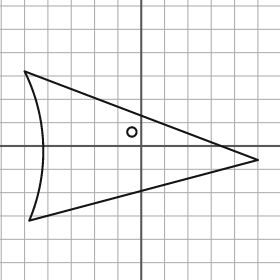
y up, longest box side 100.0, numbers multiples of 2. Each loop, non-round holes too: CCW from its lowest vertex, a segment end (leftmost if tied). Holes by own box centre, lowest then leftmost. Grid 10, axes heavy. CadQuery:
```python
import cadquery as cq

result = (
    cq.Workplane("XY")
    .moveTo(-48.0, -32.0)
    .lineTo(50.0, -6.0)
    .lineTo(-50.0, 32.0)
    .threePointArc((-42.0, 0.0), (-48.0, -32.0))
    .close()
    .moveTo(-4.0, 6.0)
    .circle(2.0)
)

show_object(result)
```